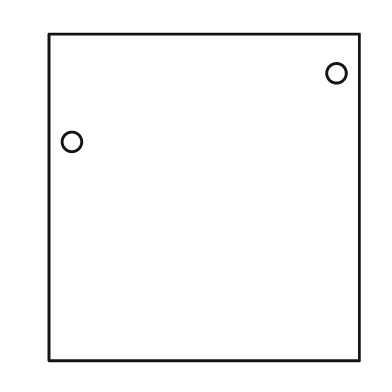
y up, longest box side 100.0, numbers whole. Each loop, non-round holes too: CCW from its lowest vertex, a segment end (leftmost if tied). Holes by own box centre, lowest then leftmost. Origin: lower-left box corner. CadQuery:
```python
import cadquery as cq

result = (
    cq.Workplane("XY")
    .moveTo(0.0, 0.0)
    .lineTo(95.0, 0.0)
    .lineTo(95.0, 100.0)
    .lineTo(0.0, 100.0)
    .close()
    .moveTo(7.0, 67.0)
    .circle(3.0)
    .moveTo(88.0, 88.0)
    .circle(3.0)
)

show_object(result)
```